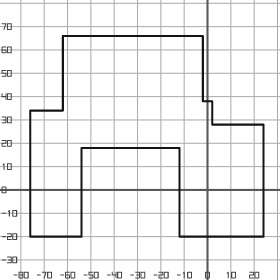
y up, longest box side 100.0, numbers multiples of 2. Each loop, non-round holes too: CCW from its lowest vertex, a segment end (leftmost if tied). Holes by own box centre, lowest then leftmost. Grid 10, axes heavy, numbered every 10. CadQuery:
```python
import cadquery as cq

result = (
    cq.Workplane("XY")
    .moveTo(-76.0, -20.0)
    .lineTo(-54.0, -20.0)
    .lineTo(-54.0, 18.0)
    .lineTo(-12.0, 18.0)
    .lineTo(-12.0, -20.0)
    .lineTo(24.0, -20.0)
    .lineTo(24.0, 28.0)
    .lineTo(2.0, 28.0)
    .lineTo(2.0, 38.0)
    .lineTo(-2.0, 38.0)
    .lineTo(-2.0, 66.0)
    .lineTo(-62.0, 66.0)
    .lineTo(-62.0, 34.0)
    .lineTo(-76.0, 34.0)
    .close()
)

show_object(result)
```